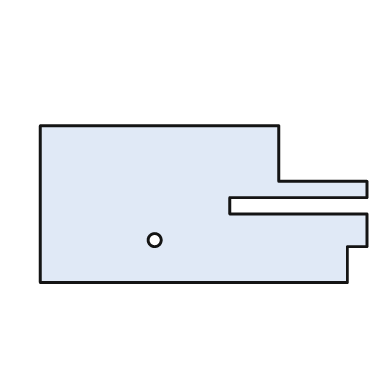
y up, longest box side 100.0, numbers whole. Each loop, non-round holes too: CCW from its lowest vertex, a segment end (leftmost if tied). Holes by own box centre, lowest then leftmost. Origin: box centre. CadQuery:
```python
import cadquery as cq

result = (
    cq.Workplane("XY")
    .moveTo(-50.0, -24.0)
    .lineTo(44.0, -24.0)
    .lineTo(44.0, -13.0)
    .lineTo(50.0, -13.0)
    .lineTo(50.0, -3.0)
    .lineTo(8.0, -3.0)
    .lineTo(8.0, 2.0)
    .lineTo(50.0, 2.0)
    .lineTo(50.0, 7.0)
    .lineTo(23.0, 7.0)
    .lineTo(23.0, 24.0)
    .lineTo(-50.0, 24.0)
    .close()
    .moveTo(-15.0, -11.0)
    .circle(2.0)
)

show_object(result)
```